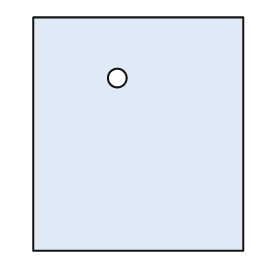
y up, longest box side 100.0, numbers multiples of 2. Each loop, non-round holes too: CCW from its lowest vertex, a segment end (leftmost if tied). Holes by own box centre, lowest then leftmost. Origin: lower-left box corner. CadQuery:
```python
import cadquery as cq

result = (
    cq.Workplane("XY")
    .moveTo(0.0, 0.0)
    .lineTo(90.0, 0.0)
    .lineTo(90.0, 100.0)
    .lineTo(0.0, 100.0)
    .close()
    .moveTo(36.0, 74.0)
    .circle(4.0)
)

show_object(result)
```